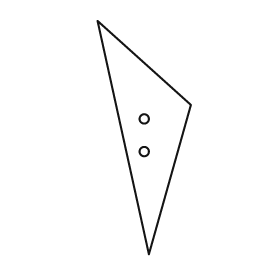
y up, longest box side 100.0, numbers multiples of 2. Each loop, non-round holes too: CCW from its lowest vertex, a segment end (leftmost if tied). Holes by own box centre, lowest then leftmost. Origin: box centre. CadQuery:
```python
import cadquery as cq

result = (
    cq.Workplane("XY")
    .moveTo(2.0, -50.0)
    .lineTo(20.0, 14.0)
    .lineTo(-20.0, 50.0)
    .close()
    .moveTo(0.0, -6.0)
    .circle(2.0)
    .moveTo(0.0, 8.0)
    .circle(2.0)
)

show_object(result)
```